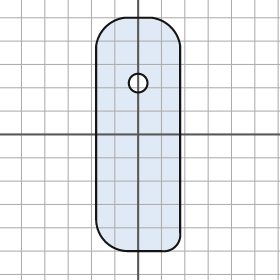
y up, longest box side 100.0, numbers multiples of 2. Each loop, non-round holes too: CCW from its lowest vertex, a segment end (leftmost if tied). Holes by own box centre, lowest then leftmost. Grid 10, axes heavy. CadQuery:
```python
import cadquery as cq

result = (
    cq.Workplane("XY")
    .moveTo(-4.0, -50.0)
    .lineTo(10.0, -50.0)
    .threePointArc((16.0, -48.0), (18.0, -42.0))
    .lineTo(18.0, 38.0)
    .threePointArc((14.0, 46.0), (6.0, 50.0))
    .lineTo(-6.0, 50.0)
    .threePointArc((-14.0, 46.0), (-18.0, 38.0))
    .lineTo(-18.0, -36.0)
    .threePointArc((-14.0, -46.0), (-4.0, -50.0))
    .close()
    .moveTo(0.0, 22.0)
    .circle(4.0)
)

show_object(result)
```